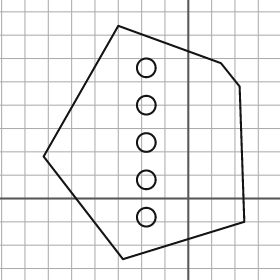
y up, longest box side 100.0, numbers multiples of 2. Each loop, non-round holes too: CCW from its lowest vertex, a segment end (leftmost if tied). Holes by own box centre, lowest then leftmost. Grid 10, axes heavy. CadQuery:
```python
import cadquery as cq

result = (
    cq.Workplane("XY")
    .moveTo(-28.0, -26.0)
    .lineTo(24.0, -10.0)
    .lineTo(22.0, 48.0)
    .lineTo(14.0, 58.0)
    .lineTo(-30.0, 74.0)
    .lineTo(-62.0, 18.0)
    .close()
    .moveTo(-18.0, -8.0)
    .circle(4.0)
    .moveTo(-18.0, 8.0)
    .circle(4.0)
    .moveTo(-18.0, 24.0)
    .circle(4.0)
    .moveTo(-18.0, 40.0)
    .circle(4.0)
    .moveTo(-18.0, 56.0)
    .circle(4.0)
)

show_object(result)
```